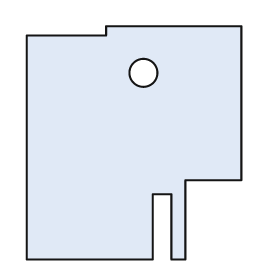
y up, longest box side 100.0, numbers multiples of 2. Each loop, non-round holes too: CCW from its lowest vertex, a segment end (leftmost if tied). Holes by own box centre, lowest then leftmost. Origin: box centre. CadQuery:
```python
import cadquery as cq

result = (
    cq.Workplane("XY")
    .moveTo(-46.0, -50.0)
    .lineTo(8.0, -50.0)
    .lineTo(8.0, -22.0)
    .lineTo(16.0, -22.0)
    .lineTo(16.0, -50.0)
    .lineTo(22.0, -50.0)
    .lineTo(22.0, -16.0)
    .lineTo(46.0, -16.0)
    .lineTo(46.0, 50.0)
    .lineTo(-12.0, 50.0)
    .lineTo(-12.0, 46.0)
    .lineTo(-46.0, 46.0)
    .close()
    .moveTo(4.0, 30.0)
    .circle(6.0)
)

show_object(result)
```